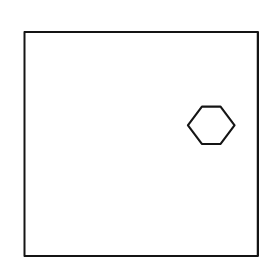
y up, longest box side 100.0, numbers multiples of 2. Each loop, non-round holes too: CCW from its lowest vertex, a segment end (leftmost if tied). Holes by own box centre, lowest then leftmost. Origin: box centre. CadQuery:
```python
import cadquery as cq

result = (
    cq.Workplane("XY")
    .moveTo(-50.0, -48.0)
    .lineTo(50.0, -48.0)
    .lineTo(50.0, 48.0)
    .lineTo(-50.0, 48.0)
    .close()
    .moveTo(26.0, 0.0)
    .lineTo(34.0, 0.0)
    .lineTo(40.0, 8.0)
    .lineTo(34.0, 16.0)
    .lineTo(26.0, 16.0)
    .lineTo(20.0, 8.0)
    .close()
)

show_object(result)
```